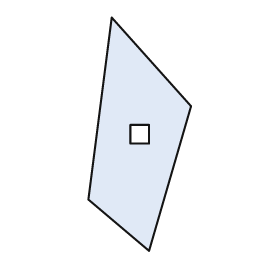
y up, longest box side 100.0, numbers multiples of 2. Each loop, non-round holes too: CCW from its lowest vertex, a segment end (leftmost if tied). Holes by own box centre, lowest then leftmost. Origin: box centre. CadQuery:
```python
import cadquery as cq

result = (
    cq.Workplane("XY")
    .moveTo(4.0, -50.0)
    .lineTo(22.0, 12.0)
    .lineTo(-12.0, 50.0)
    .lineTo(-22.0, -28.0)
    .close()
    .moveTo(-4.0, -4.0)
    .lineTo(4.0, -4.0)
    .lineTo(4.0, 4.0)
    .lineTo(-4.0, 4.0)
    .close()
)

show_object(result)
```